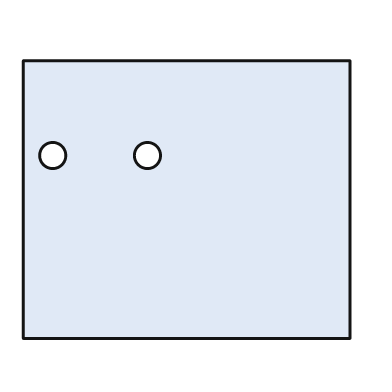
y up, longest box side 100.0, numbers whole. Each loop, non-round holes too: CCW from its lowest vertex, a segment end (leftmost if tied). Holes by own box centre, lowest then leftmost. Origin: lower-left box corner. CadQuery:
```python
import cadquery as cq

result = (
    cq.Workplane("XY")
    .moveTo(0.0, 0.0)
    .lineTo(100.0, 0.0)
    .lineTo(100.0, 85.0)
    .lineTo(0.0, 85.0)
    .close()
    .moveTo(9.0, 56.0)
    .circle(4.0)
    .moveTo(38.0, 56.0)
    .circle(4.0)
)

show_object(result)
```